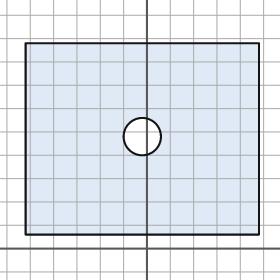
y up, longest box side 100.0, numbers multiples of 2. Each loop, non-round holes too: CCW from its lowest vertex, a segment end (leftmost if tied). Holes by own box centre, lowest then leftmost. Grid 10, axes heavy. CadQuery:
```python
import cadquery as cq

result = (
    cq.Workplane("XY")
    .moveTo(-52.0, 6.0)
    .lineTo(48.0, 6.0)
    .lineTo(48.0, 88.0)
    .lineTo(-52.0, 88.0)
    .close()
    .moveTo(-2.0, 48.0)
    .circle(8.0)
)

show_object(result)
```